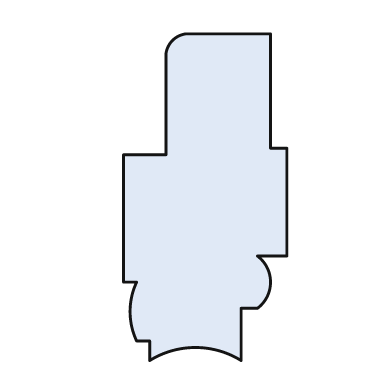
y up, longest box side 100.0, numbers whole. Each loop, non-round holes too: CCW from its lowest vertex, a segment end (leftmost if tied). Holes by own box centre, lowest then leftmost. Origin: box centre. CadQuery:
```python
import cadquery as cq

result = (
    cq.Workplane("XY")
    .moveTo(-17.0, -50.0)
    .threePointArc((-3.0, -46.0), (11.0, -50.0))
    .lineTo(11.0, -34.0)
    .lineTo(16.0, -34.0)
    .threePointArc((20.0, -26.0), (16.0, -18.0))
    .lineTo(25.0, -18.0)
    .lineTo(25.0, 15.0)
    .lineTo(20.0, 15.0)
    .lineTo(20.0, 50.0)
    .lineTo(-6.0, 50.0)
    .threePointArc((-10.0, 48.0), (-12.0, 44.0))
    .lineTo(-12.0, 13.0)
    .lineTo(-25.0, 13.0)
    .lineTo(-25.0, -26.0)
    .lineTo(-21.0, -26.0)
    .threePointArc((-23.0, -35.0), (-21.0, -44.0))
    .lineTo(-17.0, -44.0)
    .close()
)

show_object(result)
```